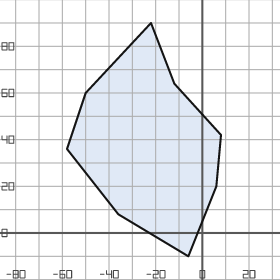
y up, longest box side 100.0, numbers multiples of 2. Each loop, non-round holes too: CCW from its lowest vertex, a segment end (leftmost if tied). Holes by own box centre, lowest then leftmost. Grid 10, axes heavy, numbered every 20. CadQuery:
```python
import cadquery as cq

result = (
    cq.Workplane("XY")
    .moveTo(-6.0, -10.0)
    .lineTo(6.0, 20.0)
    .lineTo(8.0, 42.0)
    .lineTo(-12.0, 64.0)
    .lineTo(-22.0, 90.0)
    .lineTo(-50.0, 60.0)
    .lineTo(-58.0, 36.0)
    .lineTo(-36.0, 8.0)
    .close()
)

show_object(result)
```